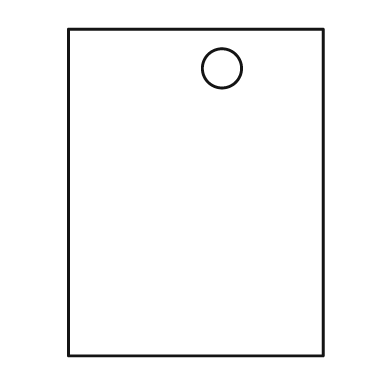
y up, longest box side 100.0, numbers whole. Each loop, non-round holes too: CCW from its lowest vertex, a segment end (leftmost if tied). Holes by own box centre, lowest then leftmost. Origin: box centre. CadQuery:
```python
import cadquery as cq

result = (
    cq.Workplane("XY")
    .moveTo(-39.0, -50.0)
    .lineTo(39.0, -50.0)
    .lineTo(39.0, 50.0)
    .lineTo(-39.0, 50.0)
    .close()
    .moveTo(8.0, 38.0)
    .circle(6.0)
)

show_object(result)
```